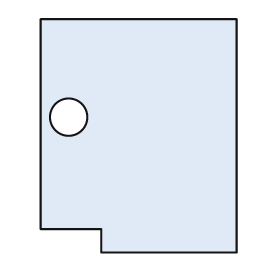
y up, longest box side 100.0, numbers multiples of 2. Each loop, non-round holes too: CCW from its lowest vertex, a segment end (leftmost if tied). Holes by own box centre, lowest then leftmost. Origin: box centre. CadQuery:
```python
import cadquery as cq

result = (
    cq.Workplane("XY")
    .moveTo(-16.0, -50.0)
    .lineTo(42.0, -50.0)
    .lineTo(42.0, 50.0)
    .lineTo(-42.0, 50.0)
    .lineTo(-42.0, -40.0)
    .lineTo(-16.0, -40.0)
    .close()
    .moveTo(-30.0, 8.0)
    .circle(8.0)
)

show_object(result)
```